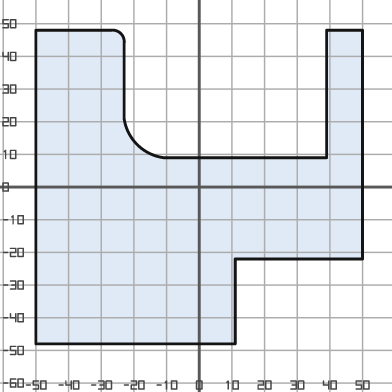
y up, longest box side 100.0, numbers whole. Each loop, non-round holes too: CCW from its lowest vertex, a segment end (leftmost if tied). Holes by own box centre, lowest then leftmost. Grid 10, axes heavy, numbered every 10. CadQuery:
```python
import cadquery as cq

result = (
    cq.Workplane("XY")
    .moveTo(-50.0, -48.0)
    .lineTo(11.0, -48.0)
    .lineTo(11.0, -22.0)
    .lineTo(50.0, -22.0)
    .lineTo(50.0, 48.0)
    .lineTo(39.0, 48.0)
    .lineTo(39.0, 9.0)
    .lineTo(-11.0, 9.0)
    .threePointArc((-19.0, 13.0), (-23.0, 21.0))
    .lineTo(-23.0, 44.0)
    .threePointArc((-24.0, 47.0), (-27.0, 48.0))
    .lineTo(-50.0, 48.0)
    .close()
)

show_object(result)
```